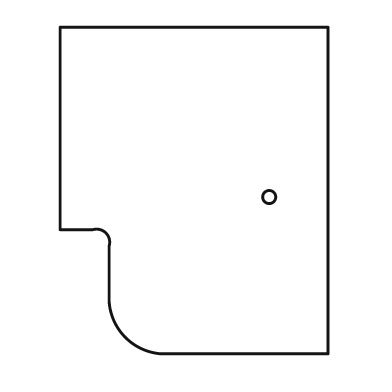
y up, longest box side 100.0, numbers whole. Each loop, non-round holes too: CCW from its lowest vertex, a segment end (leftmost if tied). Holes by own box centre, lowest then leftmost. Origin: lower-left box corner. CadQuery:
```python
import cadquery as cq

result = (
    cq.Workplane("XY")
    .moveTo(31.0, 0.0)
    .lineTo(82.0, 0.0)
    .lineTo(82.0, 100.0)
    .lineTo(0.0, 100.0)
    .lineTo(0.0, 38.0)
    .lineTo(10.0, 38.0)
    .threePointArc((14.0, 37.0), (15.0, 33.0))
    .lineTo(15.0, 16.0)
    .threePointArc((20.0, 5.0), (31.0, 0.0))
    .close()
    .moveTo(64.0, 48.0)
    .circle(2.0)
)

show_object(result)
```